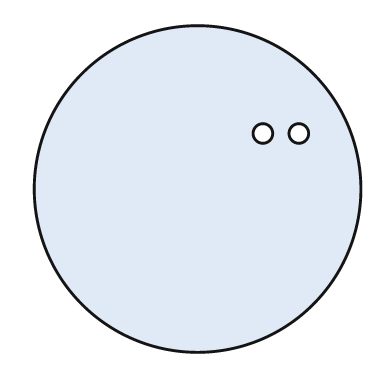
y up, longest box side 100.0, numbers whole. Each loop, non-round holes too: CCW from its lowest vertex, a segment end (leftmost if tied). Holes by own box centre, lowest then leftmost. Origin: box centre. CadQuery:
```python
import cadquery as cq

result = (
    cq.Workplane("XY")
    .moveTo(0.0, 0.0)
    .circle(50.0)
    .moveTo(20.0, 17.0)
    .circle(3.0)
    .moveTo(31.0, 17.0)
    .circle(3.0)
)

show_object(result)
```